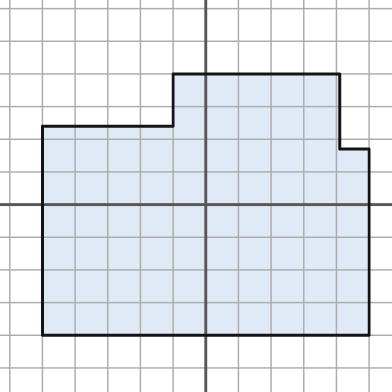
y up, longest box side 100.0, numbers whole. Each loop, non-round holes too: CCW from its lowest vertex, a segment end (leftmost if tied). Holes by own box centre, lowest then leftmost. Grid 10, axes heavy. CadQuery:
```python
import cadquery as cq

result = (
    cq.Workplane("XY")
    .moveTo(-50.0, -40.0)
    .lineTo(50.0, -40.0)
    .lineTo(50.0, 17.0)
    .lineTo(41.0, 17.0)
    .lineTo(41.0, 40.0)
    .lineTo(-10.0, 40.0)
    .lineTo(-10.0, 24.0)
    .lineTo(-50.0, 24.0)
    .close()
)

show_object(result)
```